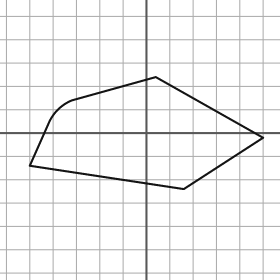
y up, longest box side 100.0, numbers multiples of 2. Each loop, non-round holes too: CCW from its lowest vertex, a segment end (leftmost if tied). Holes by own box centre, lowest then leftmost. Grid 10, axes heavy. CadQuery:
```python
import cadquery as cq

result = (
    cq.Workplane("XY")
    .moveTo(16.0, -24.0)
    .lineTo(50.0, -2.0)
    .lineTo(4.0, 24.0)
    .lineTo(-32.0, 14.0)
    .threePointArc((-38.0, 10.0), (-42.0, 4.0))
    .lineTo(-50.0, -14.0)
    .close()
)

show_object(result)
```